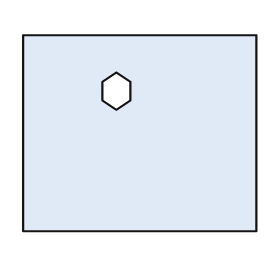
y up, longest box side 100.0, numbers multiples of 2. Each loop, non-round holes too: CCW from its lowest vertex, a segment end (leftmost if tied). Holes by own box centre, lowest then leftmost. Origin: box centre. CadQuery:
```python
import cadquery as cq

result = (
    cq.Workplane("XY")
    .moveTo(-50.0, -42.0)
    .lineTo(50.0, -42.0)
    .lineTo(50.0, 42.0)
    .lineTo(-50.0, 42.0)
    .close()
    .moveTo(-10.0, 10.0)
    .lineTo(-4.0, 14.0)
    .lineTo(-4.0, 22.0)
    .lineTo(-10.0, 26.0)
    .lineTo(-16.0, 22.0)
    .lineTo(-16.0, 14.0)
    .close()
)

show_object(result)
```